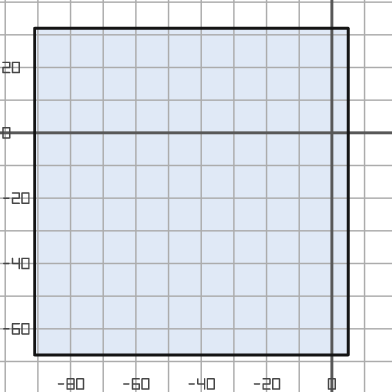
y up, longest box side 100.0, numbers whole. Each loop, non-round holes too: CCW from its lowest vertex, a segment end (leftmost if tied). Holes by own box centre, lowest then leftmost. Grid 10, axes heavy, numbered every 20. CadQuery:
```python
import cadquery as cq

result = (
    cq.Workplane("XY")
    .moveTo(-91.0, -68.0)
    .lineTo(5.0, -68.0)
    .lineTo(5.0, 32.0)
    .lineTo(-91.0, 32.0)
    .close()
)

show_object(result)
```